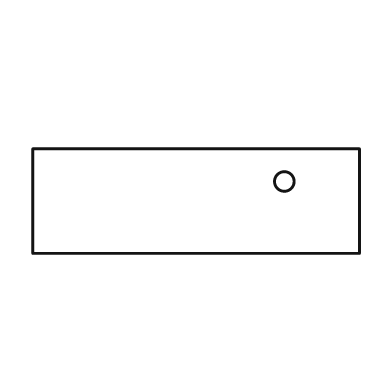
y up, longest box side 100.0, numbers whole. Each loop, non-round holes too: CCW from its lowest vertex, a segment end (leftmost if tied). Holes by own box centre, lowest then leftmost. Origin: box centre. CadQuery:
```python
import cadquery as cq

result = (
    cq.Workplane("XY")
    .moveTo(-50.0, -16.0)
    .lineTo(50.0, -16.0)
    .lineTo(50.0, 16.0)
    .lineTo(-50.0, 16.0)
    .close()
    .moveTo(27.0, 6.0)
    .circle(3.0)
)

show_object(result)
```